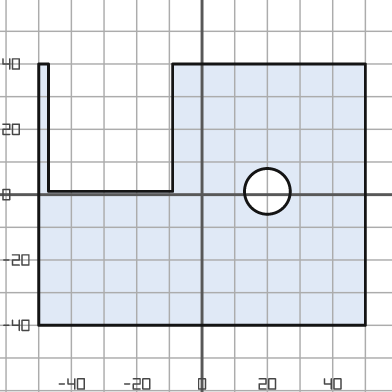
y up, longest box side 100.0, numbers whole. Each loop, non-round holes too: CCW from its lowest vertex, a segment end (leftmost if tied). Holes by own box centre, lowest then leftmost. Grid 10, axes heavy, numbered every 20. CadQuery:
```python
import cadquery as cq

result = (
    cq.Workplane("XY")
    .moveTo(-50.0, -40.0)
    .lineTo(50.0, -40.0)
    .lineTo(50.0, 40.0)
    .lineTo(-9.0, 40.0)
    .lineTo(-9.0, 1.0)
    .lineTo(-47.0, 1.0)
    .lineTo(-47.0, 40.0)
    .lineTo(-50.0, 40.0)
    .close()
    .moveTo(20.0, 1.0)
    .circle(7.0)
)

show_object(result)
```